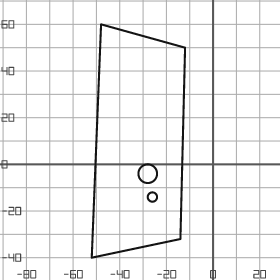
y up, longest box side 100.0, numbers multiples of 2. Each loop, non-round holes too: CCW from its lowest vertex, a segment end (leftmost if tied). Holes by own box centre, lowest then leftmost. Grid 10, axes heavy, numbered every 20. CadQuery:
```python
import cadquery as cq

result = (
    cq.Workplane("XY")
    .moveTo(-52.0, -40.0)
    .lineTo(-14.0, -32.0)
    .lineTo(-12.0, 50.0)
    .lineTo(-48.0, 60.0)
    .close()
    .moveTo(-26.0, -14.0)
    .circle(2.0)
    .moveTo(-28.0, -4.0)
    .circle(4.0)
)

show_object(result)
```